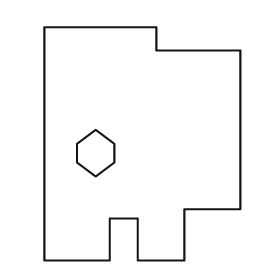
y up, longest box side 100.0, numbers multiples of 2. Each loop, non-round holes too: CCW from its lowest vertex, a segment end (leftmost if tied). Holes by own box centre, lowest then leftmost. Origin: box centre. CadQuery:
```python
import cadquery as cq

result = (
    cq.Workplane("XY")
    .moveTo(-42.0, -50.0)
    .lineTo(-14.0, -50.0)
    .lineTo(-14.0, -32.0)
    .lineTo(-2.0, -32.0)
    .lineTo(-2.0, -50.0)
    .lineTo(18.0, -50.0)
    .lineTo(18.0, -28.0)
    .lineTo(42.0, -28.0)
    .lineTo(42.0, 40.0)
    .lineTo(6.0, 40.0)
    .lineTo(6.0, 50.0)
    .lineTo(-42.0, 50.0)
    .close()
    .moveTo(-20.0, -14.0)
    .lineTo(-12.0, -8.0)
    .lineTo(-12.0, 0.0)
    .lineTo(-20.0, 6.0)
    .lineTo(-28.0, 0.0)
    .lineTo(-28.0, -8.0)
    .close()
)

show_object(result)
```